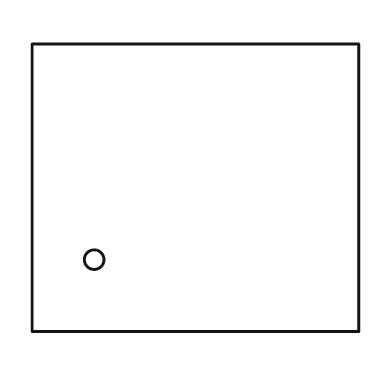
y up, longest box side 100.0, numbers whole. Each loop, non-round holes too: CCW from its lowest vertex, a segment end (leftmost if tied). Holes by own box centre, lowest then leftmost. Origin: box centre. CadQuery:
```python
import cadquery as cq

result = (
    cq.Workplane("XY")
    .moveTo(-50.0, -44.0)
    .lineTo(50.0, -44.0)
    .lineTo(50.0, 44.0)
    .lineTo(-50.0, 44.0)
    .close()
    .moveTo(-31.0, -22.0)
    .circle(3.0)
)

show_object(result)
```